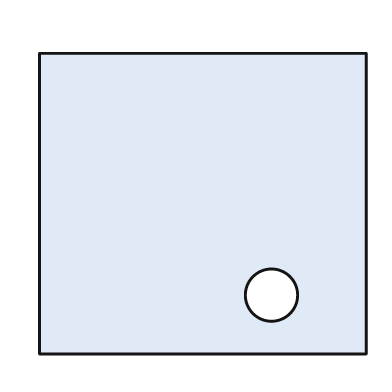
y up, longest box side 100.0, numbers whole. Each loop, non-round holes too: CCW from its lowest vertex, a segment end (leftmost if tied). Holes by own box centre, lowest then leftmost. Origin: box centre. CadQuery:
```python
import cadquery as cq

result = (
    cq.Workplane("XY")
    .moveTo(-50.0, -46.0)
    .lineTo(50.0, -46.0)
    .lineTo(50.0, 46.0)
    .lineTo(-50.0, 46.0)
    .close()
    .moveTo(21.0, -28.0)
    .circle(8.0)
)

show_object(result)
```